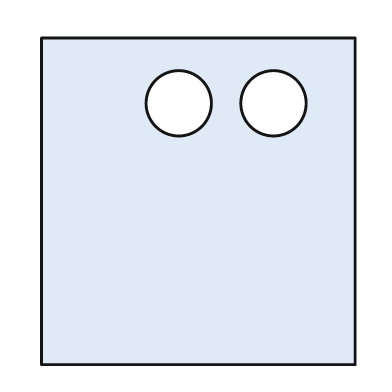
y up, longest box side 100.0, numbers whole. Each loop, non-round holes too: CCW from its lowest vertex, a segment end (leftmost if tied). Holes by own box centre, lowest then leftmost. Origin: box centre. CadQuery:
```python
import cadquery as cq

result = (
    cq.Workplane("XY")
    .moveTo(-48.0, -50.0)
    .lineTo(48.0, -50.0)
    .lineTo(48.0, 50.0)
    .lineTo(-48.0, 50.0)
    .close()
    .moveTo(-6.0, 30.0)
    .circle(10.0)
    .moveTo(23.0, 30.0)
    .circle(10.0)
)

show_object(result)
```